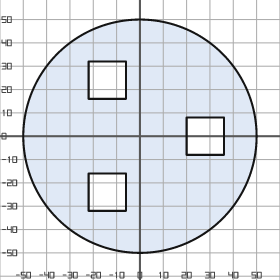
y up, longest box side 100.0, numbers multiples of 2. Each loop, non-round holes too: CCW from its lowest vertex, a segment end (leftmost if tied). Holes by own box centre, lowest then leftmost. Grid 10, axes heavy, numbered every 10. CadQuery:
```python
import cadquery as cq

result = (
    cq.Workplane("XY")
    .moveTo(0.0, 0.0)
    .circle(50.0)
    .moveTo(-22.0, -32.0)
    .lineTo(-6.0, -32.0)
    .lineTo(-6.0, -16.0)
    .lineTo(-22.0, -16.0)
    .close()
    .moveTo(20.0, -8.0)
    .lineTo(36.0, -8.0)
    .lineTo(36.0, 8.0)
    .lineTo(20.0, 8.0)
    .close()
    .moveTo(-22.0, 16.0)
    .lineTo(-6.0, 16.0)
    .lineTo(-6.0, 32.0)
    .lineTo(-22.0, 32.0)
    .close()
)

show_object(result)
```